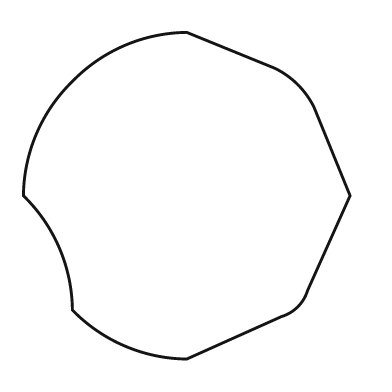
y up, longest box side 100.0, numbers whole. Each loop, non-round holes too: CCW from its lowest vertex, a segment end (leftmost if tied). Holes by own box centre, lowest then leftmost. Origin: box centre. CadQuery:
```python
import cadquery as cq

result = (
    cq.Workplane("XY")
    .moveTo(0.0, -50.0)
    .lineTo(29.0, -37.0)
    .threePointArc((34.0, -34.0), (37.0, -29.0))
    .lineTo(50.0, 0.0)
    .lineTo(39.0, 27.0)
    .threePointArc((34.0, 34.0), (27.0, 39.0))
    .lineTo(0.0, 50.0)
    .threePointArc((-19.0, 46.0), (-35.0, 35.0))
    .threePointArc((-46.0, 19.0), (-50.0, 0.0))
    .threePointArc((-39.0, -16.0), (-35.0, -35.0))
    .threePointArc((-19.0, -46.0), (0.0, -50.0))
    .close()
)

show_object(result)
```